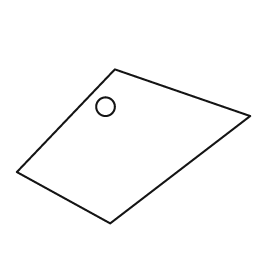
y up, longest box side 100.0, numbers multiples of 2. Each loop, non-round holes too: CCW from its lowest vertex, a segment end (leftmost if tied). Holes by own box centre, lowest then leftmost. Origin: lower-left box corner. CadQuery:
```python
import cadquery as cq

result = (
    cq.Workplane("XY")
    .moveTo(40.0, 0.0)
    .lineTo(100.0, 46.0)
    .lineTo(42.0, 66.0)
    .lineTo(0.0, 22.0)
    .close()
    .moveTo(38.0, 50.0)
    .circle(4.0)
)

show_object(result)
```